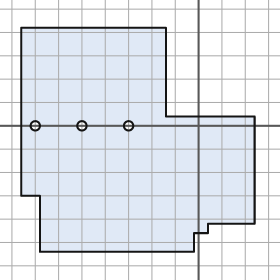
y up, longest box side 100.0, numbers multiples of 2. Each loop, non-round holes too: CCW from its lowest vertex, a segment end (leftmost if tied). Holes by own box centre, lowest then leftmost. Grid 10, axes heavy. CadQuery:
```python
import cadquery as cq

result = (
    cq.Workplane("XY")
    .moveTo(-68.0, -54.0)
    .lineTo(-2.0, -54.0)
    .lineTo(-2.0, -46.0)
    .lineTo(4.0, -46.0)
    .lineTo(4.0, -42.0)
    .lineTo(24.0, -42.0)
    .lineTo(24.0, 4.0)
    .lineTo(-14.0, 4.0)
    .lineTo(-14.0, 42.0)
    .lineTo(-76.0, 42.0)
    .lineTo(-76.0, -30.0)
    .lineTo(-68.0, -30.0)
    .close()
    .moveTo(-70.0, 0.0)
    .circle(2.0)
    .moveTo(-50.0, 0.0)
    .circle(2.0)
    .moveTo(-30.0, 0.0)
    .circle(2.0)
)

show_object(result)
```